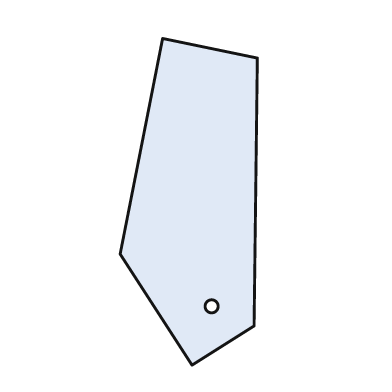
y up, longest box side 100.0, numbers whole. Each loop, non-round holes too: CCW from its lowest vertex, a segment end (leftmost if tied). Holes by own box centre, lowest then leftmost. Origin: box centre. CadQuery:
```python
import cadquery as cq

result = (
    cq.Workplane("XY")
    .moveTo(1.0, -50.0)
    .lineTo(20.0, -38.0)
    .lineTo(21.0, 44.0)
    .lineTo(-8.0, 50.0)
    .lineTo(-21.0, -16.0)
    .close()
    .moveTo(7.0, -32.0)
    .circle(2.0)
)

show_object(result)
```